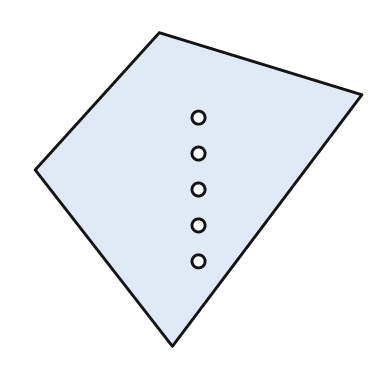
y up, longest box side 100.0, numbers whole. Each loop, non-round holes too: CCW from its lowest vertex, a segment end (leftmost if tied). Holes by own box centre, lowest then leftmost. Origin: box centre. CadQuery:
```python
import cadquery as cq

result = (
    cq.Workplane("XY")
    .moveTo(-8.0, -48.0)
    .lineTo(50.0, 29.0)
    .lineTo(-12.0, 48.0)
    .lineTo(-50.0, 6.0)
    .close()
    .moveTo(0.0, -22.0)
    .circle(2.0)
    .moveTo(0.0, -11.0)
    .circle(2.0)
    .moveTo(0.0, 0.0)
    .circle(2.0)
    .moveTo(0.0, 11.0)
    .circle(2.0)
    .moveTo(0.0, 22.0)
    .circle(2.0)
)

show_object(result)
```